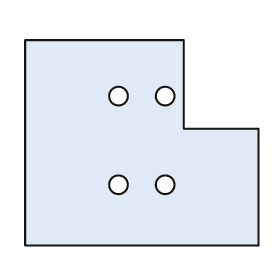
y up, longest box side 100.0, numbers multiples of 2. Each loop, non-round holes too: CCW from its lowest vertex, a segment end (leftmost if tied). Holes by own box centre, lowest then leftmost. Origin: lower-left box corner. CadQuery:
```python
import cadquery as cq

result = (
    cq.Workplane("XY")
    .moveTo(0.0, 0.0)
    .lineTo(100.0, 0.0)
    .lineTo(100.0, 50.0)
    .lineTo(68.0, 50.0)
    .lineTo(68.0, 88.0)
    .lineTo(0.0, 88.0)
    .close()
    .moveTo(40.0, 26.0)
    .circle(4.0)
    .moveTo(60.0, 26.0)
    .circle(4.0)
    .moveTo(40.0, 64.0)
    .circle(4.0)
    .moveTo(60.0, 64.0)
    .circle(4.0)
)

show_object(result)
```